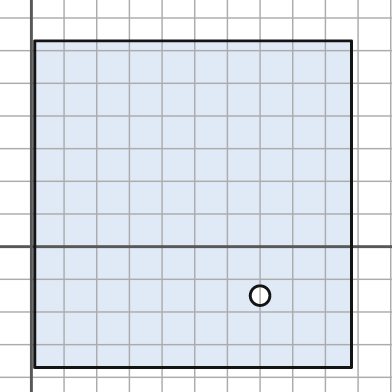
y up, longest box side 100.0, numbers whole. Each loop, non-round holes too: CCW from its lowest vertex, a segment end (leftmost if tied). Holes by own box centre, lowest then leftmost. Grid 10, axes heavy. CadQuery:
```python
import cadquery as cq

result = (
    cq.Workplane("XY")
    .moveTo(1.0, -37.0)
    .lineTo(98.0, -37.0)
    .lineTo(98.0, 63.0)
    .lineTo(1.0, 63.0)
    .close()
    .moveTo(70.0, -15.0)
    .circle(3.0)
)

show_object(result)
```